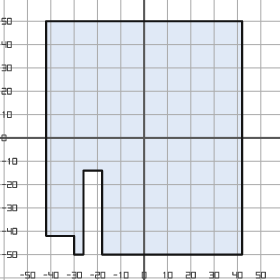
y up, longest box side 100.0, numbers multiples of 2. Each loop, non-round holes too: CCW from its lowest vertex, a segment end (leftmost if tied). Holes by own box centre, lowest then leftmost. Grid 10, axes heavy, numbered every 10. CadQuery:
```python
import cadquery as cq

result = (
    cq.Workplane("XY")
    .moveTo(-30.0, -50.0)
    .lineTo(-26.0, -50.0)
    .lineTo(-26.0, -14.0)
    .lineTo(-18.0, -14.0)
    .lineTo(-18.0, -50.0)
    .lineTo(42.0, -50.0)
    .lineTo(42.0, 50.0)
    .lineTo(-42.0, 50.0)
    .lineTo(-42.0, -42.0)
    .lineTo(-30.0, -42.0)
    .close()
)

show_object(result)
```